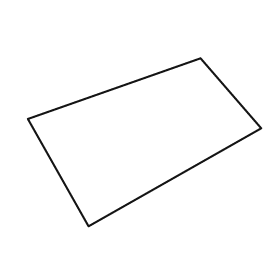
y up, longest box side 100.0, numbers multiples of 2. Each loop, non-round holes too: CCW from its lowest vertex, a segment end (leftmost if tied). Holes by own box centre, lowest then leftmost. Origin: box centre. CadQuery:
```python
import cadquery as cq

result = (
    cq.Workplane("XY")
    .moveTo(-24.0, -36.0)
    .lineTo(50.0, 6.0)
    .lineTo(24.0, 36.0)
    .lineTo(-50.0, 10.0)
    .close()
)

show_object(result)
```